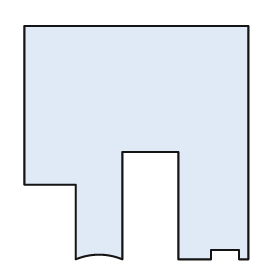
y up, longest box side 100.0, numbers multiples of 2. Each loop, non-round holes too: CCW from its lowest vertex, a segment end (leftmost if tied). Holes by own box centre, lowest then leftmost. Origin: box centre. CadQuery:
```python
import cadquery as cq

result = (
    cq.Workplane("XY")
    .moveTo(-26.0, -50.0)
    .threePointArc((-16.0, -48.0), (-6.0, -50.0))
    .lineTo(-6.0, -4.0)
    .lineTo(18.0, -4.0)
    .lineTo(18.0, -50.0)
    .lineTo(32.0, -50.0)
    .lineTo(32.0, -46.0)
    .lineTo(44.0, -46.0)
    .lineTo(44.0, -50.0)
    .lineTo(48.0, -50.0)
    .lineTo(48.0, 50.0)
    .lineTo(-48.0, 50.0)
    .lineTo(-48.0, -18.0)
    .lineTo(-26.0, -18.0)
    .close()
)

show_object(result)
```